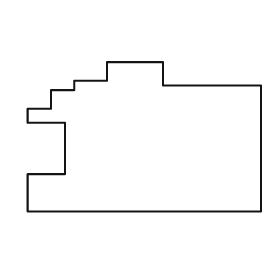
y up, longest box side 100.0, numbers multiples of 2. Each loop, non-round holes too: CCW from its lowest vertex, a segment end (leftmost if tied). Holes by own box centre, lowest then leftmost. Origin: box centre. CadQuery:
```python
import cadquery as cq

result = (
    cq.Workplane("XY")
    .moveTo(-50.0, -32.0)
    .lineTo(50.0, -32.0)
    .lineTo(50.0, 22.0)
    .lineTo(8.0, 22.0)
    .lineTo(8.0, 32.0)
    .lineTo(-16.0, 32.0)
    .lineTo(-16.0, 24.0)
    .lineTo(-30.0, 24.0)
    .lineTo(-30.0, 20.0)
    .lineTo(-40.0, 20.0)
    .lineTo(-40.0, 12.0)
    .lineTo(-50.0, 12.0)
    .lineTo(-50.0, 6.0)
    .lineTo(-34.0, 6.0)
    .lineTo(-34.0, -16.0)
    .lineTo(-50.0, -16.0)
    .close()
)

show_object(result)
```